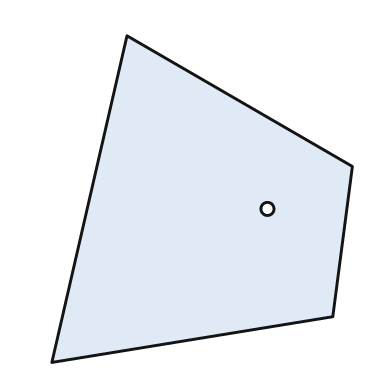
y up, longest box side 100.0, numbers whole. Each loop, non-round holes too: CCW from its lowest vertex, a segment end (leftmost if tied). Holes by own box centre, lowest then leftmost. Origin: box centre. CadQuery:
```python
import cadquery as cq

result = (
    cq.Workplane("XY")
    .moveTo(-46.0, -50.0)
    .lineTo(40.0, -36.0)
    .lineTo(46.0, 10.0)
    .lineTo(-23.0, 50.0)
    .close()
    .moveTo(20.0, -3.0)
    .circle(2.0)
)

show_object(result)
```